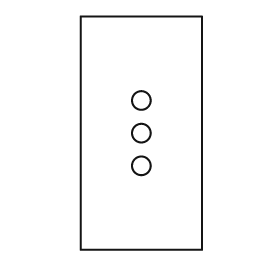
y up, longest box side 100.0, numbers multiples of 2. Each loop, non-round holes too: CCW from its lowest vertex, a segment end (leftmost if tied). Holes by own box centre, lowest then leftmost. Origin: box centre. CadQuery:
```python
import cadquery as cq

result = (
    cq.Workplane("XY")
    .moveTo(-26.0, -50.0)
    .lineTo(26.0, -50.0)
    .lineTo(26.0, 50.0)
    .lineTo(-26.0, 50.0)
    .close()
    .moveTo(0.0, -14.0)
    .circle(4.0)
    .moveTo(0.0, 0.0)
    .circle(4.0)
    .moveTo(0.0, 14.0)
    .circle(4.0)
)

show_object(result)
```